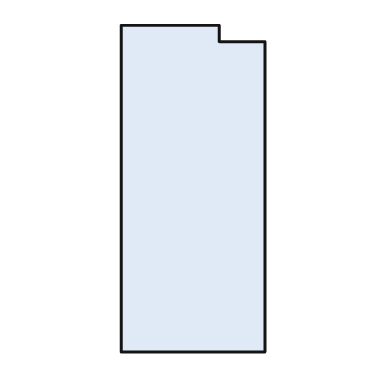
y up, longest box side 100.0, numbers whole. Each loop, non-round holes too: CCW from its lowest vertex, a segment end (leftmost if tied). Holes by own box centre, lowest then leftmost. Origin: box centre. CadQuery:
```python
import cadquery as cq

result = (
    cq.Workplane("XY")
    .moveTo(-22.0, -50.0)
    .lineTo(22.0, -50.0)
    .lineTo(22.0, 45.0)
    .lineTo(8.0, 45.0)
    .lineTo(8.0, 50.0)
    .lineTo(-22.0, 50.0)
    .close()
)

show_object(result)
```